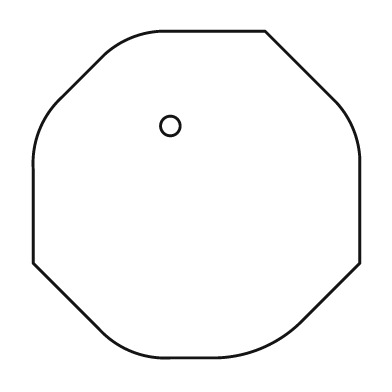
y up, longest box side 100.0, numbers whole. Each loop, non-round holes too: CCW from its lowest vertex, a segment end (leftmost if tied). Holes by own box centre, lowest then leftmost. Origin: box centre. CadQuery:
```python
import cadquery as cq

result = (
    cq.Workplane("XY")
    .moveTo(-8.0, -50.0)
    .lineTo(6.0, -50.0)
    .threePointArc((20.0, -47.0), (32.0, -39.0))
    .lineTo(50.0, -21.0)
    .lineTo(50.0, 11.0)
    .threePointArc((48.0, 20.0), (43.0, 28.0))
    .lineTo(21.0, 50.0)
    .lineTo(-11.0, 50.0)
    .threePointArc((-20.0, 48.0), (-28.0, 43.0))
    .lineTo(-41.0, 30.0)
    .threePointArc((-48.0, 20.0), (-50.0, 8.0))
    .lineTo(-50.0, -21.0)
    .lineTo(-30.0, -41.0)
    .threePointArc((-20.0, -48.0), (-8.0, -50.0))
    .close()
    .moveTo(-8.0, 21.0)
    .circle(3.0)
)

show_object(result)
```